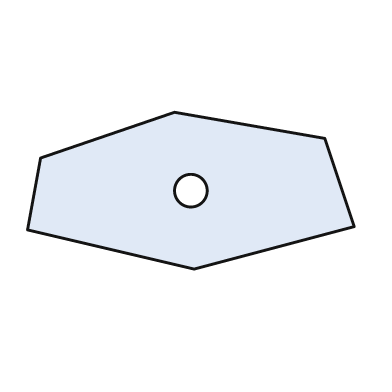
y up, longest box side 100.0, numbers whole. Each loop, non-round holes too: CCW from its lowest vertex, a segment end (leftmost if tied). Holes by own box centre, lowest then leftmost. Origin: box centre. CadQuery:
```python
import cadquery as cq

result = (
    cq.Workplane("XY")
    .moveTo(1.0, -24.0)
    .lineTo(50.0, -11.0)
    .lineTo(41.0, 16.0)
    .lineTo(-5.0, 24.0)
    .lineTo(-46.0, 10.0)
    .lineTo(-50.0, -12.0)
    .close()
    .moveTo(0.0, 0.0)
    .circle(5.0)
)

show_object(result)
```